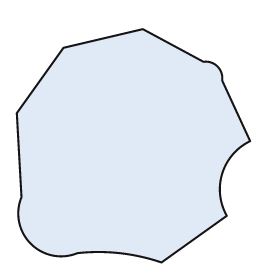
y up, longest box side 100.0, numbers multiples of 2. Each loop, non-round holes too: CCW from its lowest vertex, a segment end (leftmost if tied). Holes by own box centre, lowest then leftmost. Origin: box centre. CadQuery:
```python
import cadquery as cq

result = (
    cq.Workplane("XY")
    .moveTo(12.0, -50.0)
    .lineTo(40.0, -30.0)
    .threePointArc((38.0, -12.0), (50.0, 2.0))
    .lineTo(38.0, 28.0)
    .threePointArc((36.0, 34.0), (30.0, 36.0))
    .lineTo(4.0, 50.0)
    .lineTo(-30.0, 42.0)
    .lineTo(-50.0, 14.0)
    .lineTo(-48.0, -22.0)
    .threePointArc((-44.0, -42.0), (-24.0, -46.0))
    .threePointArc((-6.0, -46.0), (12.0, -50.0))
    .close()
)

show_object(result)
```